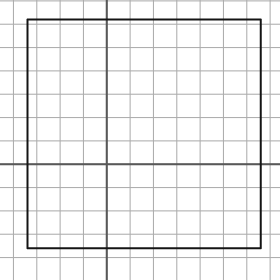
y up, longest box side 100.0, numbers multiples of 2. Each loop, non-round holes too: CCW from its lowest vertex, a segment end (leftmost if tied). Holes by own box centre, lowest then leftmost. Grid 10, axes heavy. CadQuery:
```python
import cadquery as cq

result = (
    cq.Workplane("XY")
    .moveTo(-34.0, -36.0)
    .lineTo(66.0, -36.0)
    .lineTo(66.0, 62.0)
    .lineTo(-34.0, 62.0)
    .close()
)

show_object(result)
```